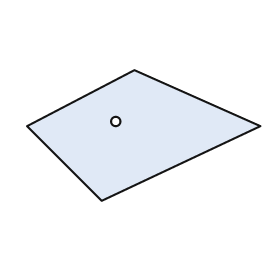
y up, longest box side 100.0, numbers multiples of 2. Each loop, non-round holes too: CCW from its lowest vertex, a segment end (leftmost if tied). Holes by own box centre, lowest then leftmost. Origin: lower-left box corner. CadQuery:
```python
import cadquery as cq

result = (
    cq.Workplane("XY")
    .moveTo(32.0, 0.0)
    .lineTo(100.0, 32.0)
    .lineTo(46.0, 56.0)
    .lineTo(0.0, 32.0)
    .close()
    .moveTo(38.0, 34.0)
    .circle(2.0)
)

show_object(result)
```